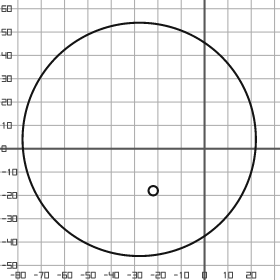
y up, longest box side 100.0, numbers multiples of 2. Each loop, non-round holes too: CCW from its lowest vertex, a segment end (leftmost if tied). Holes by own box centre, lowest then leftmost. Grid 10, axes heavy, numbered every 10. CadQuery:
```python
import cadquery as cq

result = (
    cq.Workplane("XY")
    .moveTo(-28.0, 4.0)
    .circle(50.0)
    .moveTo(-22.0, -18.0)
    .circle(2.0)
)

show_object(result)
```